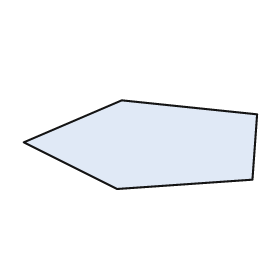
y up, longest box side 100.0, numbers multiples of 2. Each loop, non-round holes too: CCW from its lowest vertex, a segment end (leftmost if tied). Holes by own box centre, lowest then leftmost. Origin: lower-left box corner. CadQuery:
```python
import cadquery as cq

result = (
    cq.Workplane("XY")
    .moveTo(40.0, 0.0)
    .lineTo(98.0, 4.0)
    .lineTo(100.0, 32.0)
    .lineTo(42.0, 38.0)
    .lineTo(0.0, 20.0)
    .close()
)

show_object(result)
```